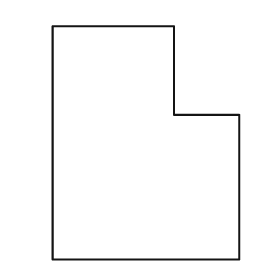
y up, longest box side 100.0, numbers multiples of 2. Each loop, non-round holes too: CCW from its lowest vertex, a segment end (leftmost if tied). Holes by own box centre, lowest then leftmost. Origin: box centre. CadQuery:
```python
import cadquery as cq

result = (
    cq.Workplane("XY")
    .moveTo(-40.0, -50.0)
    .lineTo(40.0, -50.0)
    .lineTo(40.0, 12.0)
    .lineTo(12.0, 12.0)
    .lineTo(12.0, 50.0)
    .lineTo(-40.0, 50.0)
    .close()
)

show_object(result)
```